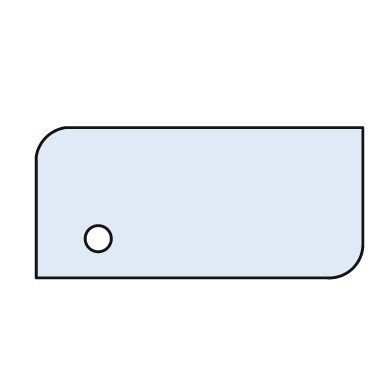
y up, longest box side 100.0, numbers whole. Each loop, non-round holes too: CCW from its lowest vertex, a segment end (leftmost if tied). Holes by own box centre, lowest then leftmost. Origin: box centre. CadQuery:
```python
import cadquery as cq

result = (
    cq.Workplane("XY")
    .moveTo(-50.0, -23.0)
    .lineTo(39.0, -23.0)
    .threePointArc((47.0, -20.0), (50.0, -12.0))
    .lineTo(50.0, 23.0)
    .lineTo(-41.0, 23.0)
    .threePointArc((-47.0, 20.0), (-50.0, 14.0))
    .close()
    .moveTo(-31.0, -11.0)
    .circle(4.0)
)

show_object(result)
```